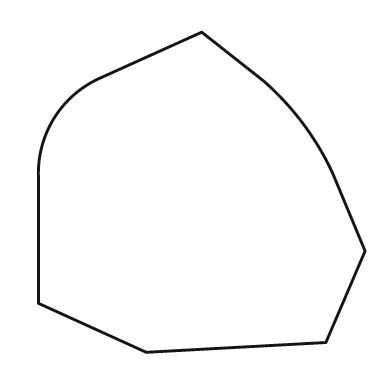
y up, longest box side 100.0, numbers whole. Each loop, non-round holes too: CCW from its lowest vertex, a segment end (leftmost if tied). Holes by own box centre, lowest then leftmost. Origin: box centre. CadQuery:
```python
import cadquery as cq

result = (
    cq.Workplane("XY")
    .moveTo(-17.0, -49.0)
    .lineTo(38.0, -46.0)
    .lineTo(50.0, -18.0)
    .lineTo(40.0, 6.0)
    .threePointArc((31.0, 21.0), (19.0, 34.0))
    .lineTo(0.0, 49.0)
    .lineTo(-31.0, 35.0)
    .threePointArc((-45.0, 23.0), (-50.0, 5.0))
    .lineTo(-50.0, -34.0)
    .close()
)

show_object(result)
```